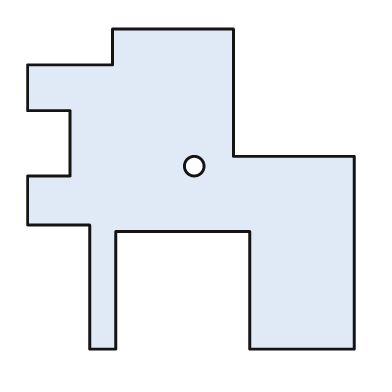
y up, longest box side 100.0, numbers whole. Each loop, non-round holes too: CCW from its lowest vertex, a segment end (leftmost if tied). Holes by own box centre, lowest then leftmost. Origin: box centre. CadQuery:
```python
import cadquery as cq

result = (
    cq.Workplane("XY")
    .moveTo(-31.0, -49.0)
    .lineTo(-23.0, -49.0)
    .lineTo(-23.0, -13.0)
    .lineTo(18.0, -13.0)
    .lineTo(18.0, -49.0)
    .lineTo(50.0, -49.0)
    .lineTo(50.0, 10.0)
    .lineTo(13.0, 10.0)
    .lineTo(13.0, 49.0)
    .lineTo(-24.0, 49.0)
    .lineTo(-24.0, 38.0)
    .lineTo(-50.0, 38.0)
    .lineTo(-50.0, 24.0)
    .lineTo(-37.0, 24.0)
    .lineTo(-37.0, 4.0)
    .lineTo(-50.0, 4.0)
    .lineTo(-50.0, -11.0)
    .lineTo(-31.0, -11.0)
    .close()
    .moveTo(1.0, 7.0)
    .circle(3.0)
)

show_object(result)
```